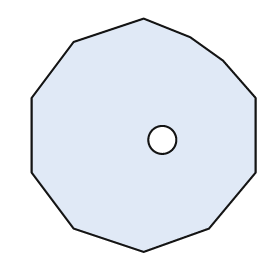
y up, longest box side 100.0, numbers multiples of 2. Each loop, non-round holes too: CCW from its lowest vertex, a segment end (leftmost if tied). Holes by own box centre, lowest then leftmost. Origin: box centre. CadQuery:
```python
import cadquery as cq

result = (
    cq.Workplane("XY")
    .moveTo(0.0, -50.0)
    .lineTo(28.0, -40.0)
    .lineTo(48.0, -16.0)
    .lineTo(48.0, 16.0)
    .lineTo(34.0, 32.0)
    .lineTo(20.0, 42.0)
    .lineTo(0.0, 50.0)
    .lineTo(-30.0, 40.0)
    .lineTo(-48.0, 16.0)
    .lineTo(-48.0, -16.0)
    .lineTo(-30.0, -40.0)
    .close()
    .moveTo(8.0, -2.0)
    .circle(6.0)
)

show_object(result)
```